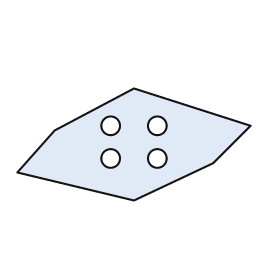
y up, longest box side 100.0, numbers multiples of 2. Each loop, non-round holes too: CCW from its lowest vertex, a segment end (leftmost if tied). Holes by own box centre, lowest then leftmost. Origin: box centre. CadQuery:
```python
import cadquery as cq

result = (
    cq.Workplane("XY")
    .moveTo(0.0, -24.0)
    .lineTo(34.0, -8.0)
    .lineTo(50.0, 8.0)
    .lineTo(0.0, 24.0)
    .lineTo(-34.0, 6.0)
    .lineTo(-50.0, -12.0)
    .close()
    .moveTo(-10.0, -6.0)
    .circle(4.0)
    .moveTo(10.0, -6.0)
    .circle(4.0)
    .moveTo(-10.0, 8.0)
    .circle(4.0)
    .moveTo(10.0, 8.0)
    .circle(4.0)
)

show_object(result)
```